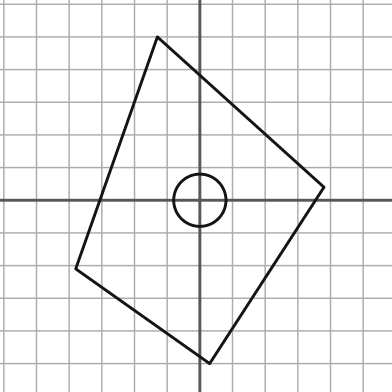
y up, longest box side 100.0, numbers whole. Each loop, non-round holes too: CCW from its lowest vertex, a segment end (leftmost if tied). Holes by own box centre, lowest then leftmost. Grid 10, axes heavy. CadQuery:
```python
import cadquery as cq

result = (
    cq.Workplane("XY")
    .moveTo(3.0, -50.0)
    .lineTo(38.0, 4.0)
    .lineTo(-13.0, 50.0)
    .lineTo(-38.0, -21.0)
    .close()
    .moveTo(0.0, 0.0)
    .circle(8.0)
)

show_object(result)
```